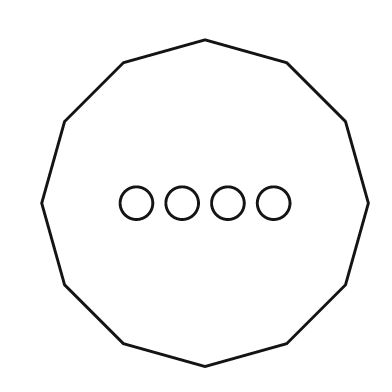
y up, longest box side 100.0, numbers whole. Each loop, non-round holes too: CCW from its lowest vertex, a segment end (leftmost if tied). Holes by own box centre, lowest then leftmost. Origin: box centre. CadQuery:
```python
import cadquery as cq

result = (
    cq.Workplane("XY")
    .moveTo(0.0, -50.0)
    .lineTo(25.0, -43.0)
    .lineTo(43.0, -25.0)
    .lineTo(50.0, 0.0)
    .lineTo(43.0, 25.0)
    .lineTo(25.0, 43.0)
    .lineTo(0.0, 50.0)
    .lineTo(-25.0, 43.0)
    .lineTo(-43.0, 25.0)
    .lineTo(-50.0, 0.0)
    .lineTo(-43.0, -25.0)
    .lineTo(-25.0, -43.0)
    .close()
    .moveTo(-21.0, 0.0)
    .circle(5.0)
    .moveTo(-7.0, 0.0)
    .circle(5.0)
    .moveTo(7.0, 0.0)
    .circle(5.0)
    .moveTo(21.0, 0.0)
    .circle(5.0)
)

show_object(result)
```